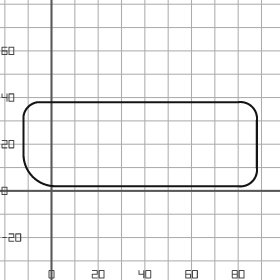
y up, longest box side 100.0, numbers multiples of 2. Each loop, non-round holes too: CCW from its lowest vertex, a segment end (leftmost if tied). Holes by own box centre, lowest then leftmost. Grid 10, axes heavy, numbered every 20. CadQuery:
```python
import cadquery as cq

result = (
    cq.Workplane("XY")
    .moveTo(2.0, 2.0)
    .lineTo(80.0, 2.0)
    .threePointArc((86.0, 4.0), (88.0, 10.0))
    .lineTo(88.0, 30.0)
    .threePointArc((86.0, 36.0), (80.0, 38.0))
    .lineTo(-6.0, 38.0)
    .threePointArc((-10.0, 36.0), (-12.0, 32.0))
    .lineTo(-12.0, 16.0)
    .threePointArc((-8.0, 6.0), (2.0, 2.0))
    .close()
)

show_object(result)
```